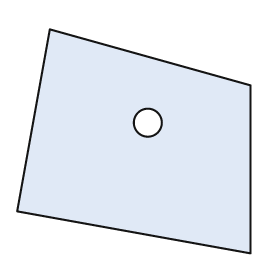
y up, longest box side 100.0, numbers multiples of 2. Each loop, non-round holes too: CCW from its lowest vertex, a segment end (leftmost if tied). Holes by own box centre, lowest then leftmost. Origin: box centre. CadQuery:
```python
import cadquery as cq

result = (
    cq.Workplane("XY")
    .moveTo(50.0, -48.0)
    .lineTo(50.0, 24.0)
    .lineTo(-36.0, 48.0)
    .lineTo(-50.0, -30.0)
    .close()
    .moveTo(6.0, 8.0)
    .circle(6.0)
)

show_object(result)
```